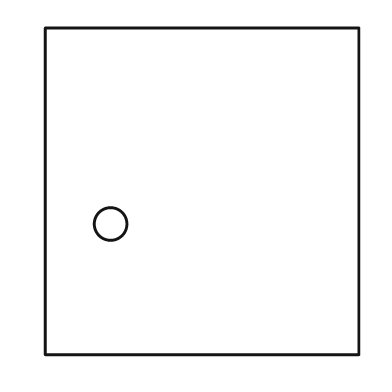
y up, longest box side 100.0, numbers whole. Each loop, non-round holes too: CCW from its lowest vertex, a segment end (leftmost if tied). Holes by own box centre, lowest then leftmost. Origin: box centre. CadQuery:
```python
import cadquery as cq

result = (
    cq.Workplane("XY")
    .moveTo(-48.0, -50.0)
    .lineTo(48.0, -50.0)
    .lineTo(48.0, 50.0)
    .lineTo(-48.0, 50.0)
    .close()
    .moveTo(-28.0, -10.0)
    .circle(5.0)
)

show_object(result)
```